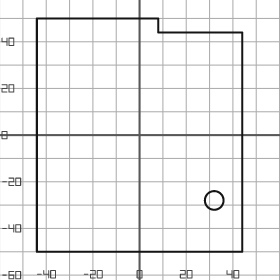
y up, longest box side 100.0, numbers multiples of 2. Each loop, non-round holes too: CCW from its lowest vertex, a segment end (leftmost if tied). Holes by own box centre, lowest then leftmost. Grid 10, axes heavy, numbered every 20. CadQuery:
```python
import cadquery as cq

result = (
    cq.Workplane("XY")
    .moveTo(-44.0, -50.0)
    .lineTo(44.0, -50.0)
    .lineTo(44.0, 44.0)
    .lineTo(8.0, 44.0)
    .lineTo(8.0, 50.0)
    .lineTo(-44.0, 50.0)
    .close()
    .moveTo(32.0, -28.0)
    .circle(4.0)
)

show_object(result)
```